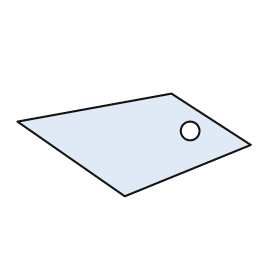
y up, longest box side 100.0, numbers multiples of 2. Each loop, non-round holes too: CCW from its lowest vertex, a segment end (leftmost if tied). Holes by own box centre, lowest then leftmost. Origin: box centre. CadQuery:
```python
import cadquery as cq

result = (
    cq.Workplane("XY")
    .moveTo(-4.0, -22.0)
    .lineTo(50.0, 0.0)
    .lineTo(16.0, 22.0)
    .lineTo(-50.0, 10.0)
    .close()
    .moveTo(24.0, 6.0)
    .circle(4.0)
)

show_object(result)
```